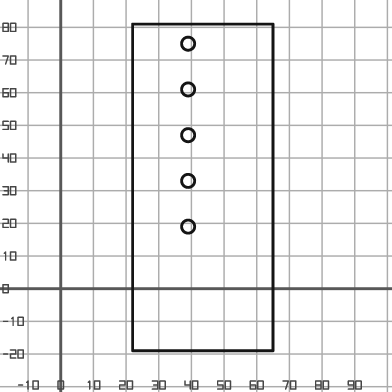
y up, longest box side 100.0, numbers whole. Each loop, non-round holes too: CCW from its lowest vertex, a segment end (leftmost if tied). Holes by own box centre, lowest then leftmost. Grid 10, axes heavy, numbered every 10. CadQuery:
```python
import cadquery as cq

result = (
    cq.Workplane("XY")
    .moveTo(22.0, -19.0)
    .lineTo(65.0, -19.0)
    .lineTo(65.0, 81.0)
    .lineTo(22.0, 81.0)
    .close()
    .moveTo(39.0, 19.0)
    .circle(2.0)
    .moveTo(39.0, 33.0)
    .circle(2.0)
    .moveTo(39.0, 47.0)
    .circle(2.0)
    .moveTo(39.0, 61.0)
    .circle(2.0)
    .moveTo(39.0, 75.0)
    .circle(2.0)
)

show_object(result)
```